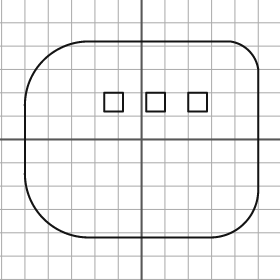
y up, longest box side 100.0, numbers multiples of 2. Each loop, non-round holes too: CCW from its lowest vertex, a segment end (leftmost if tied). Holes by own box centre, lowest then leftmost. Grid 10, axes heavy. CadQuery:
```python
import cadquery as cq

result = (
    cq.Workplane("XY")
    .moveTo(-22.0, -42.0)
    .lineTo(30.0, -42.0)
    .threePointArc((44.0, -36.0), (50.0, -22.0))
    .lineTo(50.0, 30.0)
    .threePointArc((46.0, 38.0), (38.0, 42.0))
    .lineTo(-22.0, 42.0)
    .threePointArc((-42.0, 34.0), (-50.0, 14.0))
    .lineTo(-50.0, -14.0)
    .threePointArc((-42.0, -34.0), (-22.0, -42.0))
    .close()
    .moveTo(-16.0, 12.0)
    .lineTo(-8.0, 12.0)
    .lineTo(-8.0, 20.0)
    .lineTo(-16.0, 20.0)
    .close()
    .moveTo(2.0, 12.0)
    .lineTo(10.0, 12.0)
    .lineTo(10.0, 20.0)
    .lineTo(2.0, 20.0)
    .close()
    .moveTo(20.0, 12.0)
    .lineTo(28.0, 12.0)
    .lineTo(28.0, 20.0)
    .lineTo(20.0, 20.0)
    .close()
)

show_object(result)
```